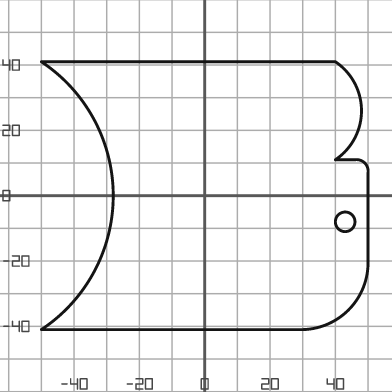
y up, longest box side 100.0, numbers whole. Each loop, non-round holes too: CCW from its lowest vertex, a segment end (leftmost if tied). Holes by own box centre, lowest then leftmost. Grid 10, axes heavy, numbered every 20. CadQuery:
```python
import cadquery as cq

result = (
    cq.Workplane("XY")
    .moveTo(-50.0, -41.0)
    .lineTo(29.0, -41.0)
    .threePointArc((44.0, -35.0), (50.0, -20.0))
    .lineTo(50.0, 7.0)
    .threePointArc((49.0, 10.0), (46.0, 11.0))
    .lineTo(40.0, 11.0)
    .threePointArc((48.0, 26.0), (40.0, 41.0))
    .lineTo(-50.0, 41.0)
    .threePointArc((-28.0, 0.0), (-50.0, -41.0))
    .close()
    .moveTo(43.0, -8.0)
    .circle(3.0)
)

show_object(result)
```